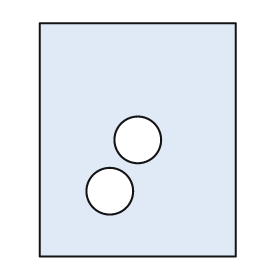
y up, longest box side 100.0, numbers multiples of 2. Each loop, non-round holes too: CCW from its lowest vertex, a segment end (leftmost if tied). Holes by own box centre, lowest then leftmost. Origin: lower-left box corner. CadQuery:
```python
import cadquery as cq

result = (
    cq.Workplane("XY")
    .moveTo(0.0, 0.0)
    .lineTo(84.0, 0.0)
    .lineTo(84.0, 100.0)
    .lineTo(0.0, 100.0)
    .close()
    .moveTo(30.0, 28.0)
    .circle(10.0)
    .moveTo(42.0, 50.0)
    .circle(10.0)
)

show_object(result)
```